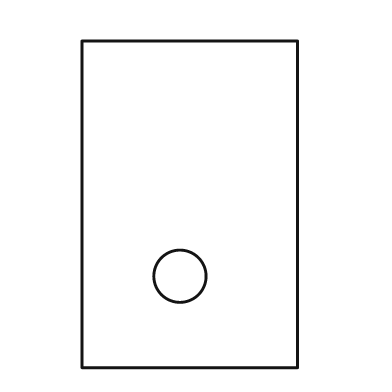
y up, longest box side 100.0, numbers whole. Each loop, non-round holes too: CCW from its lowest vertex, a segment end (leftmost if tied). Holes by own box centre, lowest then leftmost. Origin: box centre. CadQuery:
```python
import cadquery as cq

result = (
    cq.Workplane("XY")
    .moveTo(-33.0, -50.0)
    .lineTo(33.0, -50.0)
    .lineTo(33.0, 50.0)
    .lineTo(-33.0, 50.0)
    .close()
    .moveTo(-3.0, -22.0)
    .circle(8.0)
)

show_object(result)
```